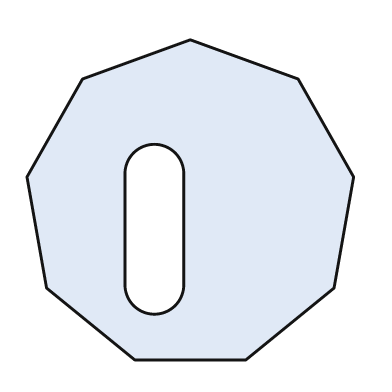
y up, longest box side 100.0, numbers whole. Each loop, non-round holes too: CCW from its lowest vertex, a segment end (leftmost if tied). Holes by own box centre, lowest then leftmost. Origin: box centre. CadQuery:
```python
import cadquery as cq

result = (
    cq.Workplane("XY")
    .moveTo(-17.0, -49.0)
    .lineTo(17.0, -49.0)
    .lineTo(44.0, -27.0)
    .lineTo(50.0, 7.0)
    .lineTo(33.0, 37.0)
    .lineTo(0.0, 49.0)
    .lineTo(-33.0, 37.0)
    .lineTo(-50.0, 7.0)
    .lineTo(-44.0, -27.0)
    .close()
    .moveTo(-20.0, -26.0)
    .threePointArc((-11.0, -35.0), (-2.0, -26.0))
    .lineTo(-2.0, 8.0)
    .threePointArc((-11.0, 17.0), (-20.0, 8.0))
    .close()
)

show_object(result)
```